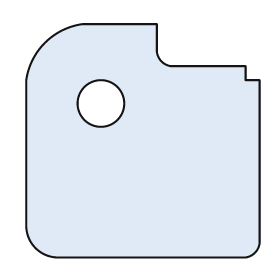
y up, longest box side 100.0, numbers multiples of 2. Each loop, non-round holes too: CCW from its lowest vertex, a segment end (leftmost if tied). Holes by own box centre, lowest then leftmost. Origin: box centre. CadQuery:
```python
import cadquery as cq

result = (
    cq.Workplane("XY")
    .moveTo(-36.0, -50.0)
    .lineTo(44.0, -50.0)
    .threePointArc((48.0, -48.0), (50.0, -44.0))
    .lineTo(50.0, 26.0)
    .lineTo(44.0, 26.0)
    .lineTo(44.0, 32.0)
    .lineTo(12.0, 32.0)
    .threePointArc((8.0, 34.0), (6.0, 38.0))
    .lineTo(6.0, 50.0)
    .lineTo(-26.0, 50.0)
    .threePointArc((-42.0, 42.0), (-50.0, 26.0))
    .lineTo(-50.0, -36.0)
    .threePointArc((-46.0, -46.0), (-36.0, -50.0))
    .close()
    .moveTo(-18.0, 16.0)
    .circle(10.0)
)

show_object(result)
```